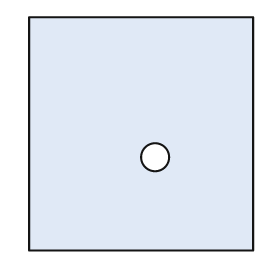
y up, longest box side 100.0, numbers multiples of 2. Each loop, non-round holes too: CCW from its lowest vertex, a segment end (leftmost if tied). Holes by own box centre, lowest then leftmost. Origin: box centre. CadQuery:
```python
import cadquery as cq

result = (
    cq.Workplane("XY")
    .moveTo(-48.0, -50.0)
    .lineTo(48.0, -50.0)
    .lineTo(48.0, 50.0)
    .lineTo(-48.0, 50.0)
    .close()
    .moveTo(6.0, -10.0)
    .circle(6.0)
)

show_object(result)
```